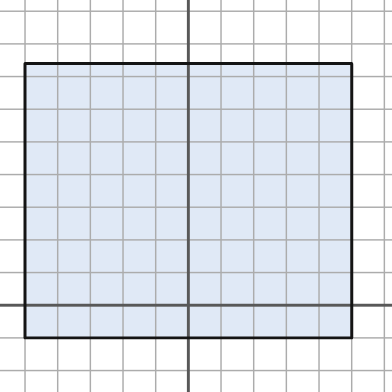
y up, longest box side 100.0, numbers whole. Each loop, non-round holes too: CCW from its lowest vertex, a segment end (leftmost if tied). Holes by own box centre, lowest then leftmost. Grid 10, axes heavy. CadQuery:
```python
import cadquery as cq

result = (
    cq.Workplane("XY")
    .moveTo(-50.0, -10.0)
    .lineTo(50.0, -10.0)
    .lineTo(50.0, 74.0)
    .lineTo(-50.0, 74.0)
    .close()
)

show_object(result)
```